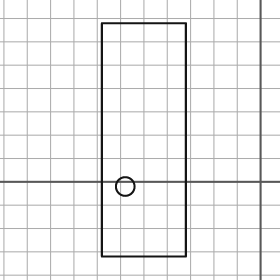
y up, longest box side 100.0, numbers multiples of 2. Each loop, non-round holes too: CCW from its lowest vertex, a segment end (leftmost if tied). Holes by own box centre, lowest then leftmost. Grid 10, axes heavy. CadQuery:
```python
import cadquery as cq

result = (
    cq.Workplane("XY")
    .moveTo(-68.0, -32.0)
    .lineTo(-32.0, -32.0)
    .lineTo(-32.0, 68.0)
    .lineTo(-68.0, 68.0)
    .close()
    .moveTo(-58.0, -2.0)
    .circle(4.0)
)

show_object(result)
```